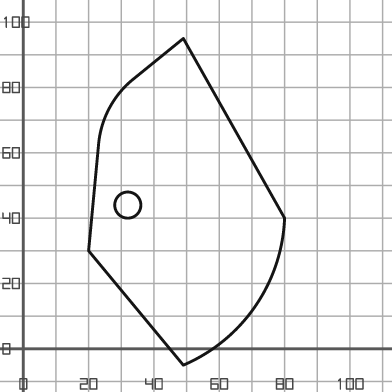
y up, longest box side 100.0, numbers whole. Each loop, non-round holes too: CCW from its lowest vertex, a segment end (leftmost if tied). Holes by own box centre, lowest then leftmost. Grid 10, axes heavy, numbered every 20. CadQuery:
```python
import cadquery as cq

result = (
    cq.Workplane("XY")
    .moveTo(49.0, -5.0)
    .threePointArc((71.0, 13.0), (80.0, 40.0))
    .lineTo(49.0, 95.0)
    .lineTo(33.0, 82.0)
    .threePointArc((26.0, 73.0), (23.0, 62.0))
    .lineTo(20.0, 30.0)
    .close()
    .moveTo(32.0, 44.0)
    .circle(4.0)
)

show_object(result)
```